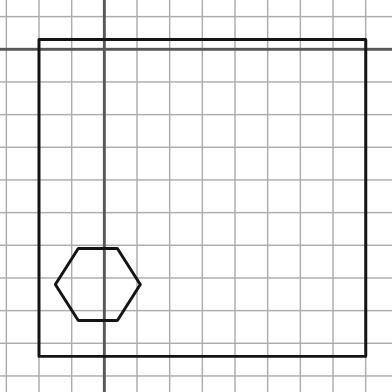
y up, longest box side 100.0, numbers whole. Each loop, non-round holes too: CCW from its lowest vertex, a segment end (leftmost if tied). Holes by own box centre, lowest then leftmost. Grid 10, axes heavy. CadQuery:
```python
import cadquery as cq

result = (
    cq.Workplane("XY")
    .moveTo(-20.0, -94.0)
    .lineTo(80.0, -94.0)
    .lineTo(80.0, 3.0)
    .lineTo(-20.0, 3.0)
    .close()
    .moveTo(-8.0, -83.0)
    .lineTo(4.0, -83.0)
    .lineTo(11.0, -72.0)
    .lineTo(4.0, -61.0)
    .lineTo(-8.0, -61.0)
    .lineTo(-15.0, -72.0)
    .close()
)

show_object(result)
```